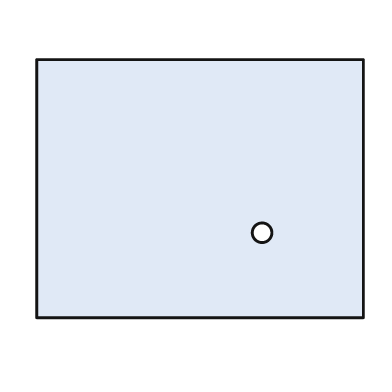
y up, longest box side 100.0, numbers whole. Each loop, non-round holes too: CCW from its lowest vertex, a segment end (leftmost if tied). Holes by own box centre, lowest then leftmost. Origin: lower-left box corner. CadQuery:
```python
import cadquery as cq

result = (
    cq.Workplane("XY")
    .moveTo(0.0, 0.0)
    .lineTo(100.0, 0.0)
    .lineTo(100.0, 79.0)
    .lineTo(0.0, 79.0)
    .close()
    .moveTo(69.0, 26.0)
    .circle(3.0)
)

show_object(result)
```